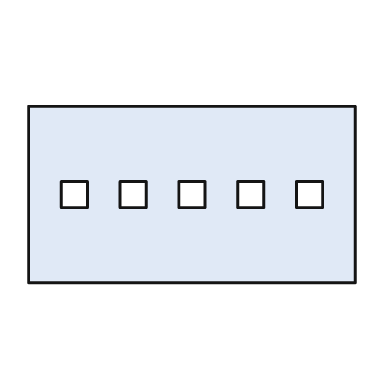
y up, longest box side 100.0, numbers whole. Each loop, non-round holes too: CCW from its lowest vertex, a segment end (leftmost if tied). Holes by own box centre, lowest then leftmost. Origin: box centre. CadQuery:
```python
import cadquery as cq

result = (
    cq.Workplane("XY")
    .moveTo(-50.0, -27.0)
    .lineTo(50.0, -27.0)
    .lineTo(50.0, 27.0)
    .lineTo(-50.0, 27.0)
    .close()
    .moveTo(-40.0, -4.0)
    .lineTo(-32.0, -4.0)
    .lineTo(-32.0, 4.0)
    .lineTo(-40.0, 4.0)
    .close()
    .moveTo(-22.0, -4.0)
    .lineTo(-14.0, -4.0)
    .lineTo(-14.0, 4.0)
    .lineTo(-22.0, 4.0)
    .close()
    .moveTo(-4.0, -4.0)
    .lineTo(4.0, -4.0)
    .lineTo(4.0, 4.0)
    .lineTo(-4.0, 4.0)
    .close()
    .moveTo(14.0, -4.0)
    .lineTo(22.0, -4.0)
    .lineTo(22.0, 4.0)
    .lineTo(14.0, 4.0)
    .close()
    .moveTo(32.0, -4.0)
    .lineTo(40.0, -4.0)
    .lineTo(40.0, 4.0)
    .lineTo(32.0, 4.0)
    .close()
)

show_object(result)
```